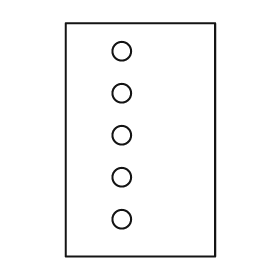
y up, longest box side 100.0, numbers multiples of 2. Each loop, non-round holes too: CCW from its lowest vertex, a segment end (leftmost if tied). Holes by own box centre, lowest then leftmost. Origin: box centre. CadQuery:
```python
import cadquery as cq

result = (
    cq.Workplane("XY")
    .moveTo(-32.0, -50.0)
    .lineTo(32.0, -50.0)
    .lineTo(32.0, 50.0)
    .lineTo(-32.0, 50.0)
    .close()
    .moveTo(-8.0, -34.0)
    .circle(4.0)
    .moveTo(-8.0, -16.0)
    .circle(4.0)
    .moveTo(-8.0, 2.0)
    .circle(4.0)
    .moveTo(-8.0, 20.0)
    .circle(4.0)
    .moveTo(-8.0, 38.0)
    .circle(4.0)
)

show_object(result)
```